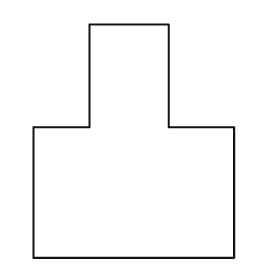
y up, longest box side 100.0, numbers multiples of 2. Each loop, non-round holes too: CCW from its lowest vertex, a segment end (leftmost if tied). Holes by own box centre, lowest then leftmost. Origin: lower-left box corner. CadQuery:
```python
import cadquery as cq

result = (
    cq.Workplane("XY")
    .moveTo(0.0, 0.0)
    .lineTo(86.0, 0.0)
    .lineTo(86.0, 56.0)
    .lineTo(58.0, 56.0)
    .lineTo(58.0, 100.0)
    .lineTo(24.0, 100.0)
    .lineTo(24.0, 56.0)
    .lineTo(0.0, 56.0)
    .close()
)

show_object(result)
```